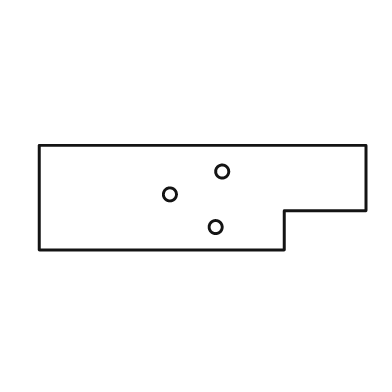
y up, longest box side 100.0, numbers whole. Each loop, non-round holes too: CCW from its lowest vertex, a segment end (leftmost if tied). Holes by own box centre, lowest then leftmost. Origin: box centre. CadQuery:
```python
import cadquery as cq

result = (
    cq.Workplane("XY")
    .moveTo(-50.0, -16.0)
    .lineTo(25.0, -16.0)
    .lineTo(25.0, -4.0)
    .lineTo(50.0, -4.0)
    .lineTo(50.0, 16.0)
    .lineTo(-50.0, 16.0)
    .close()
    .moveTo(4.0, -9.0)
    .circle(2.0)
    .moveTo(-10.0, 1.0)
    .circle(2.0)
    .moveTo(6.0, 8.0)
    .circle(2.0)
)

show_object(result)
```